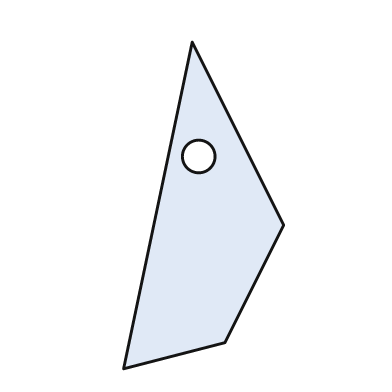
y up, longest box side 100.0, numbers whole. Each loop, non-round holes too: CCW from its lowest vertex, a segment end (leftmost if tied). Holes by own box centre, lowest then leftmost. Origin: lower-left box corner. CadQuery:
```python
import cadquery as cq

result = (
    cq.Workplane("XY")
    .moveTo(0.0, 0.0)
    .lineTo(31.0, 8.0)
    .lineTo(49.0, 44.0)
    .lineTo(21.0, 100.0)
    .close()
    .moveTo(23.0, 65.0)
    .circle(5.0)
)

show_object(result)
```